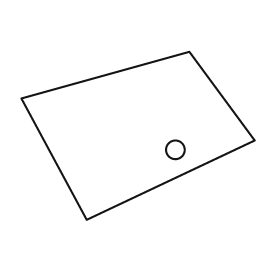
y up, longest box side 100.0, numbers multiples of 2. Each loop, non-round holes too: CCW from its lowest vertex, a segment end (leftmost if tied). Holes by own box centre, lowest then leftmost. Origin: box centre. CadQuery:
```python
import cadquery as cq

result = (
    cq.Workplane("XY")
    .moveTo(-22.0, -36.0)
    .lineTo(50.0, -2.0)
    .lineTo(22.0, 36.0)
    .lineTo(-50.0, 16.0)
    .close()
    .moveTo(16.0, -6.0)
    .circle(4.0)
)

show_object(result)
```